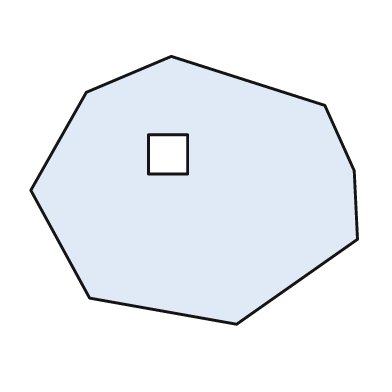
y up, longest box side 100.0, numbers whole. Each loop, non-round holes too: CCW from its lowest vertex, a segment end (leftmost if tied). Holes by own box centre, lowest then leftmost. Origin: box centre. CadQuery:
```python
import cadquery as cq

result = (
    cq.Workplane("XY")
    .moveTo(13.0, -41.0)
    .lineTo(50.0, -15.0)
    .lineTo(49.0, 6.0)
    .lineTo(40.0, 26.0)
    .lineTo(-7.0, 41.0)
    .lineTo(-33.0, 30.0)
    .lineTo(-50.0, 0.0)
    .lineTo(-32.0, -33.0)
    .close()
    .moveTo(-14.0, 5.0)
    .lineTo(-2.0, 5.0)
    .lineTo(-2.0, 17.0)
    .lineTo(-14.0, 17.0)
    .close()
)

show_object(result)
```